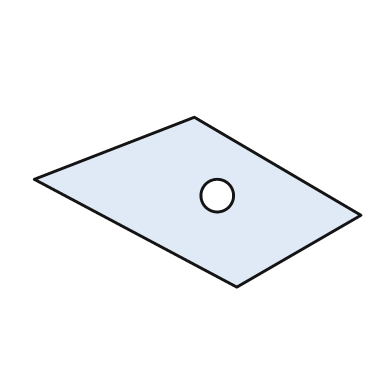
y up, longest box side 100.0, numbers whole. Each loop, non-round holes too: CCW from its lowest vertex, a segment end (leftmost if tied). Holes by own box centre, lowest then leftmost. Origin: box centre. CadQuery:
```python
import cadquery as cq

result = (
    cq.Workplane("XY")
    .moveTo(12.0, -26.0)
    .lineTo(50.0, -4.0)
    .lineTo(-1.0, 26.0)
    .lineTo(-50.0, 7.0)
    .close()
    .moveTo(6.0, 2.0)
    .circle(5.0)
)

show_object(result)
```